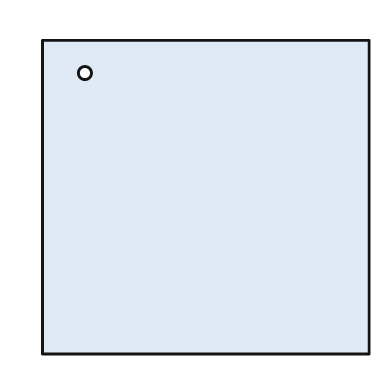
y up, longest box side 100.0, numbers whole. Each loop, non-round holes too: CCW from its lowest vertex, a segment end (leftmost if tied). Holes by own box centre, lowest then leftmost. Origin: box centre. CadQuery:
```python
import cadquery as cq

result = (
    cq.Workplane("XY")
    .moveTo(-50.0, -48.0)
    .lineTo(50.0, -48.0)
    .lineTo(50.0, 48.0)
    .lineTo(-50.0, 48.0)
    .close()
    .moveTo(-37.0, 38.0)
    .circle(2.0)
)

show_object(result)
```